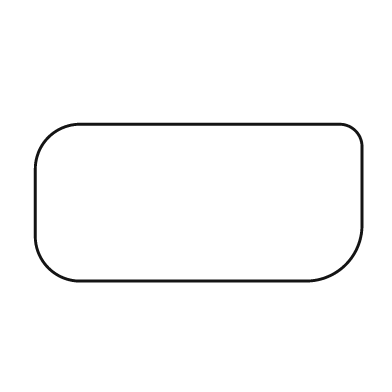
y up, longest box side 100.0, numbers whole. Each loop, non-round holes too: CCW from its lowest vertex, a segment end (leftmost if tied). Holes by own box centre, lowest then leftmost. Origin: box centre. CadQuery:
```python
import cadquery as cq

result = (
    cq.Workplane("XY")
    .moveTo(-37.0, -24.0)
    .lineTo(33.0, -24.0)
    .threePointArc((45.0, -19.0), (50.0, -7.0))
    .lineTo(50.0, 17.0)
    .threePointArc((48.0, 22.0), (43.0, 24.0))
    .lineTo(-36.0, 24.0)
    .threePointArc((-46.0, 20.0), (-50.0, 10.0))
    .lineTo(-50.0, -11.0)
    .threePointArc((-46.0, -20.0), (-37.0, -24.0))
    .close()
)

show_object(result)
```